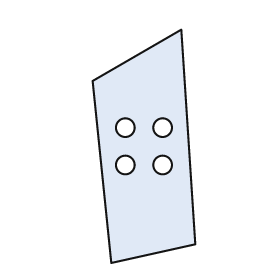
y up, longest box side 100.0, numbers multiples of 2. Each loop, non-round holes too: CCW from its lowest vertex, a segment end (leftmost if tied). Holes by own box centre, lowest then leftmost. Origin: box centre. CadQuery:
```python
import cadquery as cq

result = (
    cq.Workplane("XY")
    .moveTo(-14.0, -50.0)
    .lineTo(22.0, -42.0)
    .lineTo(16.0, 50.0)
    .lineTo(-22.0, 28.0)
    .close()
    .moveTo(-8.0, -8.0)
    .circle(4.0)
    .moveTo(8.0, -8.0)
    .circle(4.0)
    .moveTo(-8.0, 8.0)
    .circle(4.0)
    .moveTo(8.0, 8.0)
    .circle(4.0)
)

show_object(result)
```